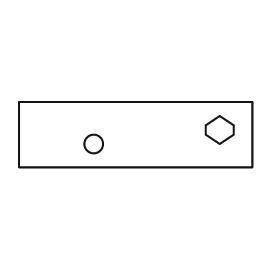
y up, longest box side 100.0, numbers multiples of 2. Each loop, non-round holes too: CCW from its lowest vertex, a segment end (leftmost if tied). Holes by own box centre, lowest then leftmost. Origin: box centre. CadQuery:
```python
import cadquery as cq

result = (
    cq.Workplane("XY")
    .moveTo(-50.0, -14.0)
    .lineTo(50.0, -14.0)
    .lineTo(50.0, 14.0)
    .lineTo(-50.0, 14.0)
    .close()
    .moveTo(-18.0, -4.0)
    .circle(4.0)
    .moveTo(36.0, -4.0)
    .lineTo(42.0, 0.0)
    .lineTo(42.0, 4.0)
    .lineTo(36.0, 8.0)
    .lineTo(30.0, 4.0)
    .lineTo(30.0, 0.0)
    .close()
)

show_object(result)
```